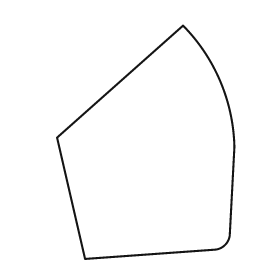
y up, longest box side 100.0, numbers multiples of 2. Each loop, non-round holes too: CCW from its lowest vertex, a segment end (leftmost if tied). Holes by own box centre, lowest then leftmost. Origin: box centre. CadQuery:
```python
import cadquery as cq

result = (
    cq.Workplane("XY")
    .moveTo(-26.0, -50.0)
    .lineTo(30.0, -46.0)
    .threePointArc((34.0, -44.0), (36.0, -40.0))
    .lineTo(38.0, -2.0)
    .threePointArc((32.0, 26.0), (16.0, 50.0))
    .lineTo(-38.0, 2.0)
    .close()
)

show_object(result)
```